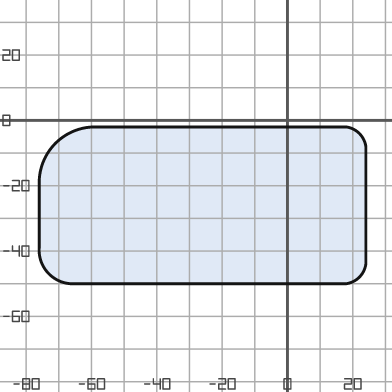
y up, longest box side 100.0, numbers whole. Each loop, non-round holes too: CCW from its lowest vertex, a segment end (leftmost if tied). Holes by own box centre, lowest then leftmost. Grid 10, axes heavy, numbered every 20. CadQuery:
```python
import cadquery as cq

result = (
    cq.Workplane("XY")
    .moveTo(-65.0, -50.0)
    .lineTo(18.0, -50.0)
    .threePointArc((22.0, -48.0), (24.0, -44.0))
    .lineTo(24.0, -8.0)
    .threePointArc((22.0, -4.0), (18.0, -2.0))
    .lineTo(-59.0, -2.0)
    .threePointArc((-71.0, -7.0), (-76.0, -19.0))
    .lineTo(-76.0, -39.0)
    .threePointArc((-73.0, -47.0), (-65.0, -50.0))
    .close()
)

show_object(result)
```